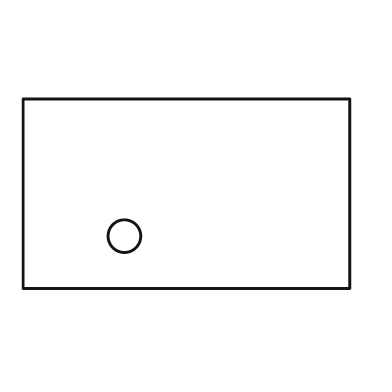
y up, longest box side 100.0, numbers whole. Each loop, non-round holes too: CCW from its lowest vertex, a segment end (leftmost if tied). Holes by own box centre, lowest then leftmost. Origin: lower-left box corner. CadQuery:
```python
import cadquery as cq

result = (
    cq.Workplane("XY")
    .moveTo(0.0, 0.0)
    .lineTo(100.0, 0.0)
    .lineTo(100.0, 58.0)
    .lineTo(0.0, 58.0)
    .close()
    .moveTo(31.0, 16.0)
    .circle(5.0)
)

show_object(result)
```